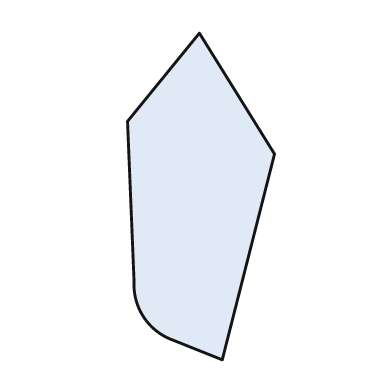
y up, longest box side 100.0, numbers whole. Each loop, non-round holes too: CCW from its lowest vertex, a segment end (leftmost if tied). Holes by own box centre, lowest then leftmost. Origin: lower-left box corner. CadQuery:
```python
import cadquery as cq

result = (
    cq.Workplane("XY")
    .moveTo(29.0, 0.0)
    .lineTo(45.0, 63.0)
    .lineTo(22.0, 100.0)
    .lineTo(0.0, 73.0)
    .lineTo(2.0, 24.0)
    .threePointArc((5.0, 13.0), (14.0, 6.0))
    .close()
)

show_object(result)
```